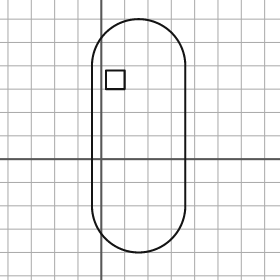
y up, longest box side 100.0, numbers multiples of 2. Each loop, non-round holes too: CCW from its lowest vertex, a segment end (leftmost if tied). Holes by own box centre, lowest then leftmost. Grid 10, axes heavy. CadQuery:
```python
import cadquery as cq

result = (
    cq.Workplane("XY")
    .moveTo(-4.0, -20.0)
    .threePointArc((16.0, -40.0), (36.0, -20.0))
    .lineTo(36.0, 40.0)
    .threePointArc((16.0, 60.0), (-4.0, 40.0))
    .close()
    .moveTo(2.0, 30.0)
    .lineTo(10.0, 30.0)
    .lineTo(10.0, 38.0)
    .lineTo(2.0, 38.0)
    .close()
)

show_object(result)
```